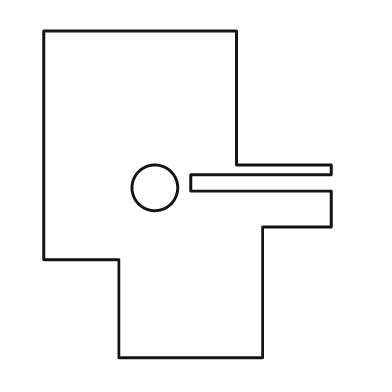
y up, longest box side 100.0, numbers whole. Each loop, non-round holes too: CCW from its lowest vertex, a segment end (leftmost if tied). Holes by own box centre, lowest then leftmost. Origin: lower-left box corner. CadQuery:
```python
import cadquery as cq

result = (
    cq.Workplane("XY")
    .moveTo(23.0, 0.0)
    .lineTo(67.0, 0.0)
    .lineTo(67.0, 40.0)
    .lineTo(88.0, 40.0)
    .lineTo(88.0, 51.0)
    .lineTo(45.0, 51.0)
    .lineTo(45.0, 56.0)
    .lineTo(88.0, 56.0)
    .lineTo(88.0, 59.0)
    .lineTo(59.0, 59.0)
    .lineTo(59.0, 100.0)
    .lineTo(0.0, 100.0)
    .lineTo(0.0, 30.0)
    .lineTo(23.0, 30.0)
    .close()
    .moveTo(34.0, 52.0)
    .circle(7.0)
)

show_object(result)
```